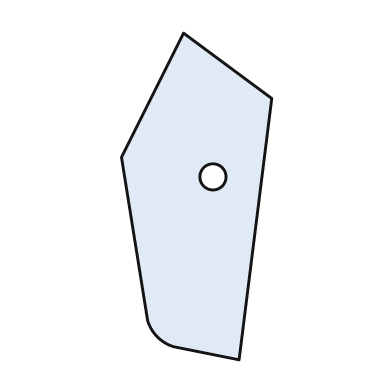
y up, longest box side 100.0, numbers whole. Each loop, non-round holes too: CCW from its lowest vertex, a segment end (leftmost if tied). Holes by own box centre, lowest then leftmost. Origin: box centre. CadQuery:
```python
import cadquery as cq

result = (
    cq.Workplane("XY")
    .moveTo(13.0, -50.0)
    .lineTo(23.0, 30.0)
    .lineTo(-4.0, 50.0)
    .lineTo(-23.0, 12.0)
    .lineTo(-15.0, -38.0)
    .threePointArc((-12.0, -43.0), (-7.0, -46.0))
    .close()
    .moveTo(5.0, 6.0)
    .circle(4.0)
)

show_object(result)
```